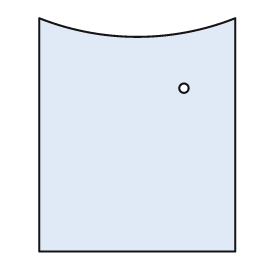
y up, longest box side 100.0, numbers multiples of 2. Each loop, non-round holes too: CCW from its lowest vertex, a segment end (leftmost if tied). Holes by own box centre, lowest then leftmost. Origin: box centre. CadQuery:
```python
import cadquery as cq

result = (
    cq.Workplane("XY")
    .moveTo(-42.0, -50.0)
    .lineTo(42.0, -50.0)
    .lineTo(42.0, 50.0)
    .threePointArc((0.0, 42.0), (-42.0, 50.0))
    .close()
    .moveTo(20.0, 20.0)
    .circle(2.0)
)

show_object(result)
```